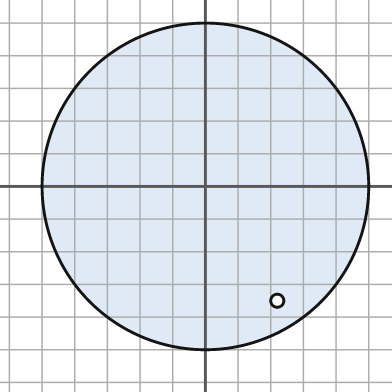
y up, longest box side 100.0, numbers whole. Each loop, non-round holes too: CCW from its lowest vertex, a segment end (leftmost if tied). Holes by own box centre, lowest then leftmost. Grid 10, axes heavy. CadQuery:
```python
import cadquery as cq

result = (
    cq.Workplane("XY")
    .moveTo(0.0, 0.0)
    .circle(50.0)
    .moveTo(22.0, -35.0)
    .circle(2.0)
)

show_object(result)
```